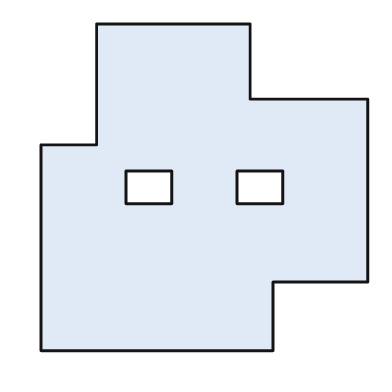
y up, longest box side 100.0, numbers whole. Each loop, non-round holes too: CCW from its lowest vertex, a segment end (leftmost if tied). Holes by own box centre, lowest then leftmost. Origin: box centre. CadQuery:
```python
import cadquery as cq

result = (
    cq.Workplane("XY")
    .moveTo(-50.0, -50.0)
    .lineTo(21.0, -50.0)
    .lineTo(21.0, -29.0)
    .lineTo(50.0, -29.0)
    .lineTo(50.0, 27.0)
    .lineTo(14.0, 27.0)
    .lineTo(14.0, 50.0)
    .lineTo(-33.0, 50.0)
    .lineTo(-33.0, 13.0)
    .lineTo(-50.0, 13.0)
    .close()
    .moveTo(-24.0, -5.0)
    .lineTo(-10.0, -5.0)
    .lineTo(-10.0, 5.0)
    .lineTo(-24.0, 5.0)
    .close()
    .moveTo(10.0, -5.0)
    .lineTo(24.0, -5.0)
    .lineTo(24.0, 5.0)
    .lineTo(10.0, 5.0)
    .close()
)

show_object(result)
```